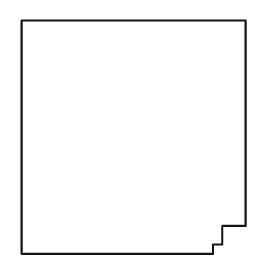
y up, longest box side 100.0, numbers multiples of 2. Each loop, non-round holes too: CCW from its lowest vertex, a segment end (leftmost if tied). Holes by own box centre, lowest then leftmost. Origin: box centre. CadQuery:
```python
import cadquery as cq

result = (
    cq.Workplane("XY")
    .moveTo(-48.0, -50.0)
    .lineTo(34.0, -50.0)
    .lineTo(34.0, -46.0)
    .lineTo(38.0, -46.0)
    .lineTo(38.0, -38.0)
    .lineTo(48.0, -38.0)
    .lineTo(48.0, 50.0)
    .lineTo(-48.0, 50.0)
    .close()
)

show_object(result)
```